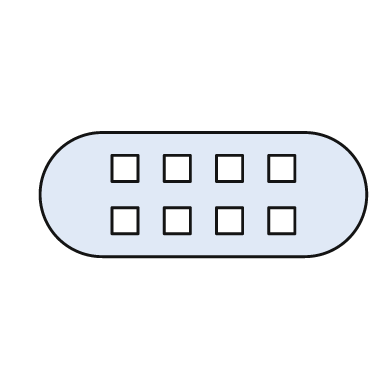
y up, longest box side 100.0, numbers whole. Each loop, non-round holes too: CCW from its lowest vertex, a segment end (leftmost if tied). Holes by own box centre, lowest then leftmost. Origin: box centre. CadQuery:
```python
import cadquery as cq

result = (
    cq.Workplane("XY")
    .moveTo(-31.0, -19.0)
    .lineTo(31.0, -19.0)
    .threePointArc((50.0, 0.0), (31.0, 19.0))
    .lineTo(-31.0, 19.0)
    .threePointArc((-50.0, 0.0), (-31.0, -19.0))
    .close()
    .moveTo(-28.0, -12.0)
    .lineTo(-20.0, -12.0)
    .lineTo(-20.0, -4.0)
    .lineTo(-28.0, -4.0)
    .close()
    .moveTo(-12.0, -12.0)
    .lineTo(-4.0, -12.0)
    .lineTo(-4.0, -4.0)
    .lineTo(-12.0, -4.0)
    .close()
    .moveTo(4.0, -12.0)
    .lineTo(12.0, -12.0)
    .lineTo(12.0, -4.0)
    .lineTo(4.0, -4.0)
    .close()
    .moveTo(20.0, -12.0)
    .lineTo(28.0, -12.0)
    .lineTo(28.0, -4.0)
    .lineTo(20.0, -4.0)
    .close()
    .moveTo(-28.0, 4.0)
    .lineTo(-20.0, 4.0)
    .lineTo(-20.0, 12.0)
    .lineTo(-28.0, 12.0)
    .close()
    .moveTo(-12.0, 4.0)
    .lineTo(-4.0, 4.0)
    .lineTo(-4.0, 12.0)
    .lineTo(-12.0, 12.0)
    .close()
    .moveTo(4.0, 4.0)
    .lineTo(12.0, 4.0)
    .lineTo(12.0, 12.0)
    .lineTo(4.0, 12.0)
    .close()
    .moveTo(20.0, 4.0)
    .lineTo(28.0, 4.0)
    .lineTo(28.0, 12.0)
    .lineTo(20.0, 12.0)
    .close()
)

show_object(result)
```